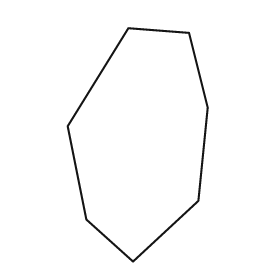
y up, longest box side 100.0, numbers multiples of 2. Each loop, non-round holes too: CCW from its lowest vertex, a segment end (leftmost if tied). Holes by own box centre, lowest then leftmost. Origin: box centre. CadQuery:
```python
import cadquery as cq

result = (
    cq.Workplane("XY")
    .moveTo(-2.0, -50.0)
    .lineTo(26.0, -24.0)
    .lineTo(30.0, 16.0)
    .lineTo(22.0, 48.0)
    .lineTo(-4.0, 50.0)
    .lineTo(-30.0, 8.0)
    .lineTo(-22.0, -32.0)
    .close()
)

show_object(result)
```